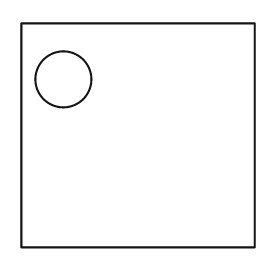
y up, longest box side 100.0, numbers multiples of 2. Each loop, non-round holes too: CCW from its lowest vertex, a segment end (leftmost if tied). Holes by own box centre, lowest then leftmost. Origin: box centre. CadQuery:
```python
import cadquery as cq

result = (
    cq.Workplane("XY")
    .moveTo(-50.0, -48.0)
    .lineTo(50.0, -48.0)
    .lineTo(50.0, 48.0)
    .lineTo(-50.0, 48.0)
    .close()
    .moveTo(-32.0, 24.0)
    .circle(12.0)
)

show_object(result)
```